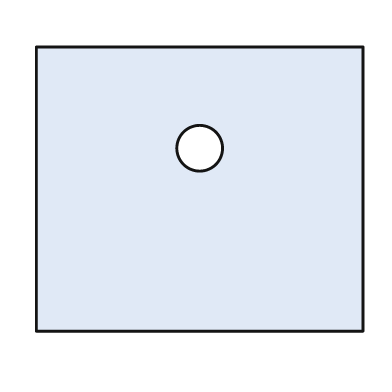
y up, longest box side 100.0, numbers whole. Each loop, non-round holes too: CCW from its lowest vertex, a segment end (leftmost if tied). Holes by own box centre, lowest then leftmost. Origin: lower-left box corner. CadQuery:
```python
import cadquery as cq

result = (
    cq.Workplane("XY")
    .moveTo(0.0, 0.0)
    .lineTo(100.0, 0.0)
    .lineTo(100.0, 87.0)
    .lineTo(0.0, 87.0)
    .close()
    .moveTo(50.0, 56.0)
    .circle(7.0)
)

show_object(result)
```